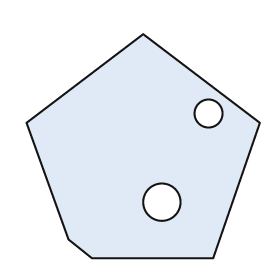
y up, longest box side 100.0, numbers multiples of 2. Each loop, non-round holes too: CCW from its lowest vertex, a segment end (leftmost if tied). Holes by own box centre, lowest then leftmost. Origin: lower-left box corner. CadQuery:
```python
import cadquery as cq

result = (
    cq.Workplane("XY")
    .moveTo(28.0, 0.0)
    .lineTo(80.0, 0.0)
    .lineTo(100.0, 58.0)
    .lineTo(50.0, 96.0)
    .lineTo(0.0, 58.0)
    .lineTo(18.0, 8.0)
    .close()
    .moveTo(58.0, 24.0)
    .circle(8.0)
    .moveTo(78.0, 62.0)
    .circle(6.0)
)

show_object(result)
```